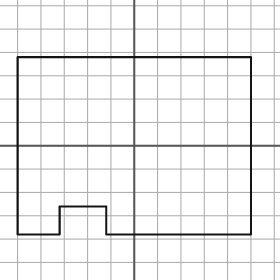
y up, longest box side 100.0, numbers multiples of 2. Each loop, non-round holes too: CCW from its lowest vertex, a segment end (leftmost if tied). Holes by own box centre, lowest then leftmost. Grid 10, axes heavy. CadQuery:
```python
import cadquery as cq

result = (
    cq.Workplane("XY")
    .moveTo(-50.0, -38.0)
    .lineTo(-32.0, -38.0)
    .lineTo(-32.0, -26.0)
    .lineTo(-12.0, -26.0)
    .lineTo(-12.0, -38.0)
    .lineTo(50.0, -38.0)
    .lineTo(50.0, 38.0)
    .lineTo(-50.0, 38.0)
    .close()
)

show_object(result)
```